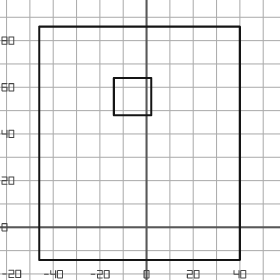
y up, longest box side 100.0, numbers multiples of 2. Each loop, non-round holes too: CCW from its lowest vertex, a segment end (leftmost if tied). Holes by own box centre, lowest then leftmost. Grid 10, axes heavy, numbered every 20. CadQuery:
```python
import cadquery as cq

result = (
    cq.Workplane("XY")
    .moveTo(-46.0, -14.0)
    .lineTo(40.0, -14.0)
    .lineTo(40.0, 86.0)
    .lineTo(-46.0, 86.0)
    .close()
    .moveTo(-14.0, 48.0)
    .lineTo(2.0, 48.0)
    .lineTo(2.0, 64.0)
    .lineTo(-14.0, 64.0)
    .close()
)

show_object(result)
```